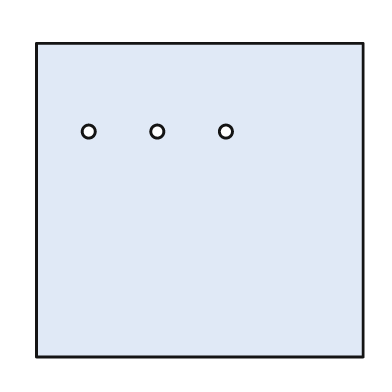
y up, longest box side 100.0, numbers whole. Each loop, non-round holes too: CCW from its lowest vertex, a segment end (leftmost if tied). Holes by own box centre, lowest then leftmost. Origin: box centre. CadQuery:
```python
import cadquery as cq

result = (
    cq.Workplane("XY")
    .moveTo(-50.0, -48.0)
    .lineTo(50.0, -48.0)
    .lineTo(50.0, 48.0)
    .lineTo(-50.0, 48.0)
    .close()
    .moveTo(-34.0, 21.0)
    .circle(2.0)
    .moveTo(-13.0, 21.0)
    .circle(2.0)
    .moveTo(8.0, 21.0)
    .circle(2.0)
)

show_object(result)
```